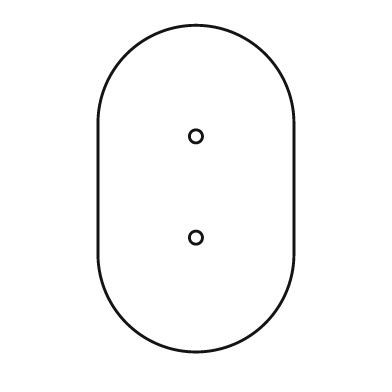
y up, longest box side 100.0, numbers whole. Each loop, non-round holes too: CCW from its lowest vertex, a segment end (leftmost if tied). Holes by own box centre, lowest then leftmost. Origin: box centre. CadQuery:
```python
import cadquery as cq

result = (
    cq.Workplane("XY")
    .moveTo(-30.0, -20.0)
    .threePointArc((0.0, -50.0), (30.0, -20.0))
    .lineTo(30.0, 20.0)
    .threePointArc((0.0, 50.0), (-30.0, 20.0))
    .close()
    .moveTo(0.0, -15.0)
    .circle(2.0)
    .moveTo(0.0, 16.0)
    .circle(2.0)
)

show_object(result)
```